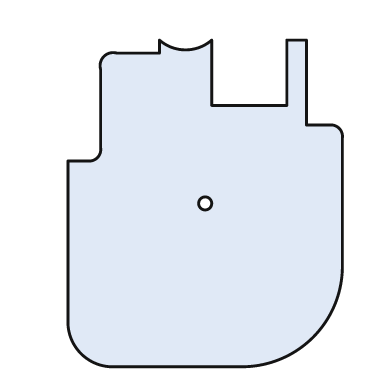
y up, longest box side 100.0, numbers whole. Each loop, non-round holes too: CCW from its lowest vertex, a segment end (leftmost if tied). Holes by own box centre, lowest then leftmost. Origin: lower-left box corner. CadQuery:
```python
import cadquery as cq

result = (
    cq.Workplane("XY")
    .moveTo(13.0, 0.0)
    .lineTo(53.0, 0.0)
    .threePointArc((75.0, 9.0), (84.0, 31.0))
    .lineTo(84.0, 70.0)
    .threePointArc((83.0, 73.0), (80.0, 74.0))
    .lineTo(73.0, 74.0)
    .lineTo(73.0, 100.0)
    .lineTo(67.0, 100.0)
    .lineTo(67.0, 80.0)
    .lineTo(44.0, 80.0)
    .lineTo(44.0, 100.0)
    .threePointArc((36.0, 97.0), (28.0, 100.0))
    .lineTo(28.0, 96.0)
    .lineTo(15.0, 96.0)
    .threePointArc((11.0, 95.0), (10.0, 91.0))
    .lineTo(10.0, 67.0)
    .threePointArc((9.0, 64.0), (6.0, 63.0))
    .lineTo(0.0, 63.0)
    .lineTo(0.0, 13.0)
    .threePointArc((4.0, 4.0), (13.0, 0.0))
    .close()
    .moveTo(42.0, 50.0)
    .circle(2.0)
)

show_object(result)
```